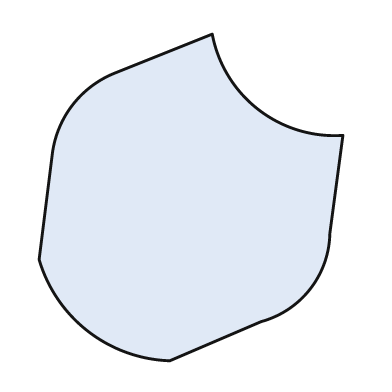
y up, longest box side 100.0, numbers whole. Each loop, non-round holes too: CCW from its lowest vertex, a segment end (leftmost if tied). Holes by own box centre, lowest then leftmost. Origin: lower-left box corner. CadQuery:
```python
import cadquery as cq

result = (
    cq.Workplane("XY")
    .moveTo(40.0, 0.0)
    .lineTo(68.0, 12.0)
    .threePointArc((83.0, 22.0), (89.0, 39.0))
    .lineTo(93.0, 69.0)
    .threePointArc((67.0, 77.0), (53.0, 100.0))
    .lineTo(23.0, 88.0)
    .threePointArc((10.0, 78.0), (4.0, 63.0))
    .lineTo(0.0, 31.0)
    .threePointArc((15.0, 9.0), (40.0, 0.0))
    .close()
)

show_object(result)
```